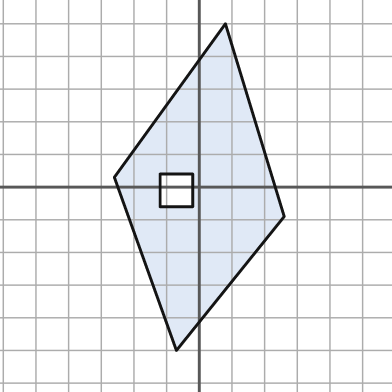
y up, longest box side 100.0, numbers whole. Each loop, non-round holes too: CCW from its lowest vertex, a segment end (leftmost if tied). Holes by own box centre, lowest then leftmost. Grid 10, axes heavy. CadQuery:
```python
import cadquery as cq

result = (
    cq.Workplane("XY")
    .moveTo(-7.0, -50.0)
    .lineTo(26.0, -9.0)
    .lineTo(8.0, 50.0)
    .lineTo(-26.0, 3.0)
    .close()
    .moveTo(-12.0, -6.0)
    .lineTo(-2.0, -6.0)
    .lineTo(-2.0, 4.0)
    .lineTo(-12.0, 4.0)
    .close()
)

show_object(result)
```